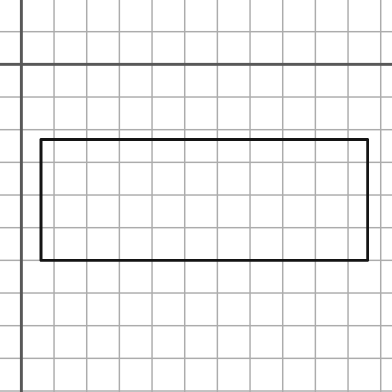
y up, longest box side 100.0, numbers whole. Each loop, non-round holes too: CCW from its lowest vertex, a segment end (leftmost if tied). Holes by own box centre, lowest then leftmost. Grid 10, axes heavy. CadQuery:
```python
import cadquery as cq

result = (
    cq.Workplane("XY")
    .moveTo(6.0, -60.0)
    .lineTo(106.0, -60.0)
    .lineTo(106.0, -23.0)
    .lineTo(6.0, -23.0)
    .close()
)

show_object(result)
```